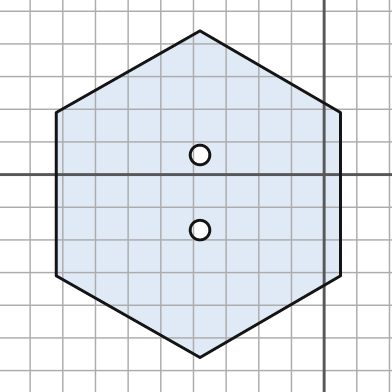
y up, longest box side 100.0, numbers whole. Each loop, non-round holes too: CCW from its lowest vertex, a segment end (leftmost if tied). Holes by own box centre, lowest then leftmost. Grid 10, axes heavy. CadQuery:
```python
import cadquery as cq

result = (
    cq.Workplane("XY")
    .moveTo(-38.0, -56.0)
    .lineTo(5.0, -31.0)
    .lineTo(5.0, 19.0)
    .lineTo(-38.0, 44.0)
    .lineTo(-82.0, 19.0)
    .lineTo(-82.0, -31.0)
    .close()
    .moveTo(-38.0, -17.0)
    .circle(3.0)
    .moveTo(-38.0, 6.0)
    .circle(3.0)
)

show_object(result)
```